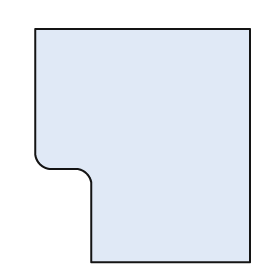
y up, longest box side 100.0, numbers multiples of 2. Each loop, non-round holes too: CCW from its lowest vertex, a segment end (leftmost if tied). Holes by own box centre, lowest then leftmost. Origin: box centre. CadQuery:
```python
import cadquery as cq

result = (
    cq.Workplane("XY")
    .moveTo(-22.0, -50.0)
    .lineTo(46.0, -50.0)
    .lineTo(46.0, 50.0)
    .lineTo(-46.0, 50.0)
    .lineTo(-46.0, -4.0)
    .threePointArc((-44.0, -8.0), (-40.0, -10.0))
    .lineTo(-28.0, -10.0)
    .threePointArc((-24.0, -12.0), (-22.0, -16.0))
    .close()
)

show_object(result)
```